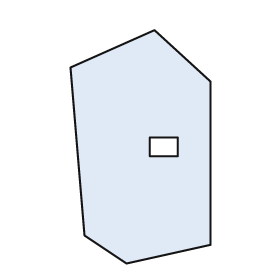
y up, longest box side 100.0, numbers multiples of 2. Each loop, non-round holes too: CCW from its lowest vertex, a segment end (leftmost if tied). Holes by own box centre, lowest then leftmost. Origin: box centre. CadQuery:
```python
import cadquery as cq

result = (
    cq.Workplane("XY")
    .moveTo(-6.0, -50.0)
    .lineTo(30.0, -42.0)
    .lineTo(30.0, 28.0)
    .lineTo(6.0, 50.0)
    .lineTo(-30.0, 34.0)
    .lineTo(-24.0, -38.0)
    .close()
    .moveTo(4.0, -4.0)
    .lineTo(16.0, -4.0)
    .lineTo(16.0, 4.0)
    .lineTo(4.0, 4.0)
    .close()
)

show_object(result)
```